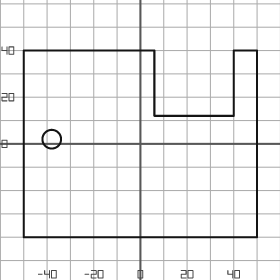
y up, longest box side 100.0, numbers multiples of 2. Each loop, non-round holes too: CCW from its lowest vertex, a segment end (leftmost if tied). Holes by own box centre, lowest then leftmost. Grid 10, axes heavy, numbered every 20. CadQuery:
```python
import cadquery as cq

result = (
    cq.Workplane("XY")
    .moveTo(-50.0, -40.0)
    .lineTo(50.0, -40.0)
    .lineTo(50.0, 40.0)
    .lineTo(40.0, 40.0)
    .lineTo(40.0, 12.0)
    .lineTo(6.0, 12.0)
    .lineTo(6.0, 40.0)
    .lineTo(-50.0, 40.0)
    .close()
    .moveTo(-38.0, 2.0)
    .circle(4.0)
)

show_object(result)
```